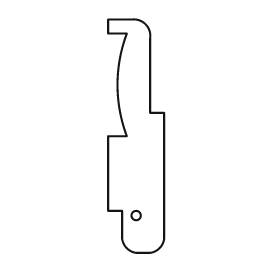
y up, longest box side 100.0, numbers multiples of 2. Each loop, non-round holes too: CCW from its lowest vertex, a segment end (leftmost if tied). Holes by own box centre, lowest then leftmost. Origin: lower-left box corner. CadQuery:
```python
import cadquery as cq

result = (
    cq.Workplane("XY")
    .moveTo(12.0, 0.0)
    .lineTo(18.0, 0.0)
    .threePointArc((22.0, 2.0), (24.0, 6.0))
    .lineTo(24.0, 60.0)
    .lineTo(18.0, 60.0)
    .lineTo(18.0, 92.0)
    .threePointArc((16.0, 98.0), (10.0, 100.0))
    .lineTo(0.0, 100.0)
    .lineTo(0.0, 94.0)
    .lineTo(8.0, 94.0)
    .threePointArc((4.0, 72.0), (8.0, 50.0))
    .lineTo(0.0, 50.0)
    .lineTo(0.0, 18.0)
    .lineTo(6.0, 18.0)
    .lineTo(6.0, 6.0)
    .threePointArc((8.0, 2.0), (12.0, 0.0))
    .close()
    .moveTo(12.0, 16.0)
    .circle(2.0)
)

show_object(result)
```